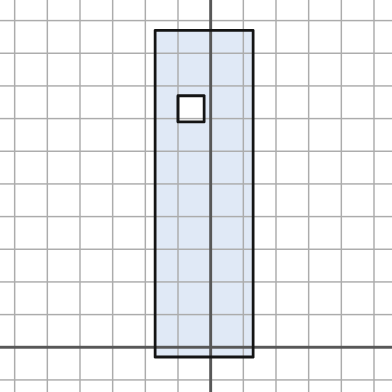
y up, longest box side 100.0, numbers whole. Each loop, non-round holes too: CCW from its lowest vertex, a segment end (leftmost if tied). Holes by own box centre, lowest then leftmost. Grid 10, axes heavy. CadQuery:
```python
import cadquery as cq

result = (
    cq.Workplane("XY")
    .moveTo(-17.0, -3.0)
    .lineTo(13.0, -3.0)
    .lineTo(13.0, 97.0)
    .lineTo(-17.0, 97.0)
    .close()
    .moveTo(-10.0, 69.0)
    .lineTo(-2.0, 69.0)
    .lineTo(-2.0, 77.0)
    .lineTo(-10.0, 77.0)
    .close()
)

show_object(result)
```